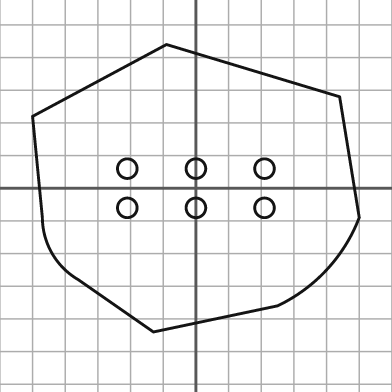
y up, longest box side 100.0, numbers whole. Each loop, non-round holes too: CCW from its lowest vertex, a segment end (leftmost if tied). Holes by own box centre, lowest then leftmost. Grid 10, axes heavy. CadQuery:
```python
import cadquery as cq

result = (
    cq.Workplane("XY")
    .moveTo(-13.0, -44.0)
    .lineTo(25.0, -36.0)
    .threePointArc((40.0, -25.0), (50.0, -9.0))
    .lineTo(44.0, 28.0)
    .lineTo(-9.0, 44.0)
    .lineTo(-50.0, 22.0)
    .lineTo(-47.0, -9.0)
    .threePointArc((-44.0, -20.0), (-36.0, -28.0))
    .close()
    .moveTo(-21.0, -6.0)
    .circle(3.0)
    .moveTo(0.0, -6.0)
    .circle(3.0)
    .moveTo(21.0, -6.0)
    .circle(3.0)
    .moveTo(-21.0, 6.0)
    .circle(3.0)
    .moveTo(0.0, 6.0)
    .circle(3.0)
    .moveTo(21.0, 6.0)
    .circle(3.0)
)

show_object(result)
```